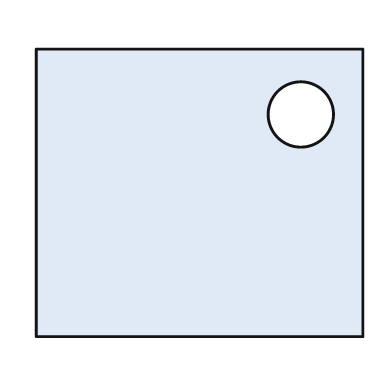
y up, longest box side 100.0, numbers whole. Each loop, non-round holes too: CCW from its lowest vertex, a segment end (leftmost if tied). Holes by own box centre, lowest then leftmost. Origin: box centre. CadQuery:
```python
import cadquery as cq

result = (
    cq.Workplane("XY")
    .moveTo(-50.0, -44.0)
    .lineTo(50.0, -44.0)
    .lineTo(50.0, 44.0)
    .lineTo(-50.0, 44.0)
    .close()
    .moveTo(31.0, 24.0)
    .circle(10.0)
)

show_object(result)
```